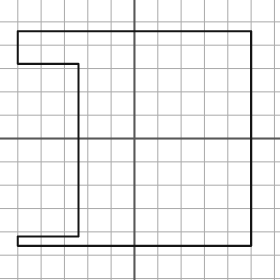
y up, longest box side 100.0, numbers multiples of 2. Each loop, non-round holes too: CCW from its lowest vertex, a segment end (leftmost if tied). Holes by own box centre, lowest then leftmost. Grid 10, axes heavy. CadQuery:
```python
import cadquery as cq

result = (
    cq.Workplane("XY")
    .moveTo(-50.0, -46.0)
    .lineTo(50.0, -46.0)
    .lineTo(50.0, 46.0)
    .lineTo(-50.0, 46.0)
    .lineTo(-50.0, 32.0)
    .lineTo(-24.0, 32.0)
    .lineTo(-24.0, -42.0)
    .lineTo(-50.0, -42.0)
    .close()
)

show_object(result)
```